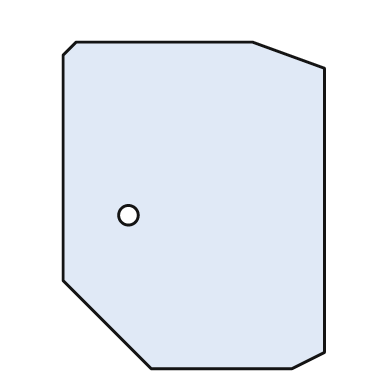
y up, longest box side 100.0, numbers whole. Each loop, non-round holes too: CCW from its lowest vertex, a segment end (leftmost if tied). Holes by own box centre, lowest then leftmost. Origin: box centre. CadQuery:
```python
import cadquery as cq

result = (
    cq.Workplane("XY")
    .moveTo(-13.0, -50.0)
    .lineTo(30.0, -50.0)
    .lineTo(40.0, -45.0)
    .lineTo(40.0, 42.0)
    .lineTo(18.0, 50.0)
    .lineTo(-36.0, 50.0)
    .lineTo(-40.0, 46.0)
    .lineTo(-40.0, -23.0)
    .close()
    .moveTo(-20.0, -3.0)
    .circle(3.0)
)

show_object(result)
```